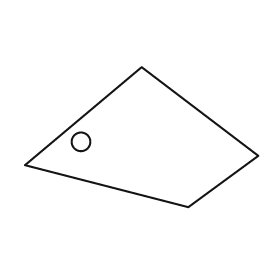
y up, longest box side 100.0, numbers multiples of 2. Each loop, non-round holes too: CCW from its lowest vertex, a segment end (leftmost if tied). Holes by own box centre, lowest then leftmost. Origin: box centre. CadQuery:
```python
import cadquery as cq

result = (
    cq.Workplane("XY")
    .moveTo(20.0, -30.0)
    .lineTo(50.0, -8.0)
    .lineTo(0.0, 30.0)
    .lineTo(-50.0, -12.0)
    .close()
    .moveTo(-26.0, -2.0)
    .circle(4.0)
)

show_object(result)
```